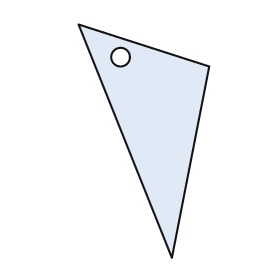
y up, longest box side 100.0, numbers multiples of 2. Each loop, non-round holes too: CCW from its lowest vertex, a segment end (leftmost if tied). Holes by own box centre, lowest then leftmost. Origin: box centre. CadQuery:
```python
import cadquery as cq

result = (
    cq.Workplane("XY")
    .moveTo(12.0, -50.0)
    .lineTo(28.0, 32.0)
    .lineTo(-28.0, 50.0)
    .close()
    .moveTo(-10.0, 36.0)
    .circle(4.0)
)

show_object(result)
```